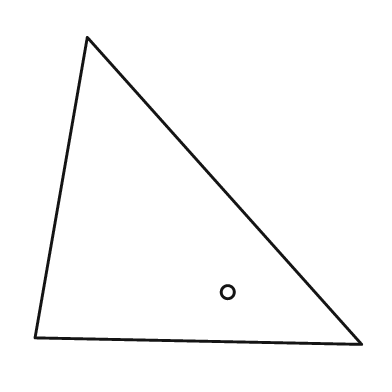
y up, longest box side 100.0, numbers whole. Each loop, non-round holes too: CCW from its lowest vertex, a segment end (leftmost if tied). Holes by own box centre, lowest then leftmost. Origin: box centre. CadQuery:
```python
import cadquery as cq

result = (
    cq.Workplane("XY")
    .moveTo(50.0, -47.0)
    .lineTo(-34.0, 47.0)
    .lineTo(-50.0, -45.0)
    .close()
    .moveTo(9.0, -31.0)
    .circle(2.0)
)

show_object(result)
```